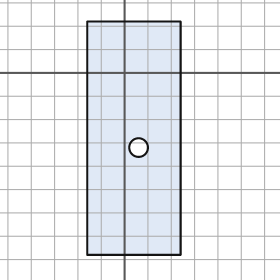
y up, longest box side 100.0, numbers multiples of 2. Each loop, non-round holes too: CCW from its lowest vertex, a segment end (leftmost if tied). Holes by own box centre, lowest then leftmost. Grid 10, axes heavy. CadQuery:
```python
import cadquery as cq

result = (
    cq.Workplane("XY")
    .moveTo(-16.0, -78.0)
    .lineTo(24.0, -78.0)
    .lineTo(24.0, 22.0)
    .lineTo(-16.0, 22.0)
    .close()
    .moveTo(6.0, -32.0)
    .circle(4.0)
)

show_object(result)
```